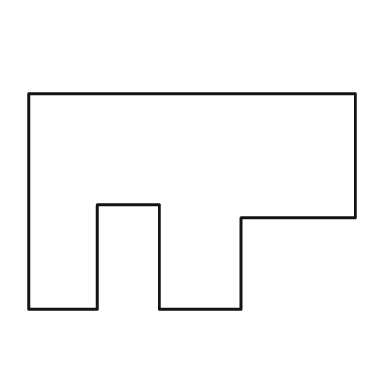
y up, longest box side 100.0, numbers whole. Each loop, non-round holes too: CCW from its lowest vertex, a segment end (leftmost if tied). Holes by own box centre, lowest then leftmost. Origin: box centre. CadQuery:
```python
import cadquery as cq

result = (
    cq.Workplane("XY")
    .moveTo(-50.0, -33.0)
    .lineTo(-29.0, -33.0)
    .lineTo(-29.0, -1.0)
    .lineTo(-10.0, -1.0)
    .lineTo(-10.0, -33.0)
    .lineTo(15.0, -33.0)
    .lineTo(15.0, -5.0)
    .lineTo(50.0, -5.0)
    .lineTo(50.0, 33.0)
    .lineTo(-50.0, 33.0)
    .close()
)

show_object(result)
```